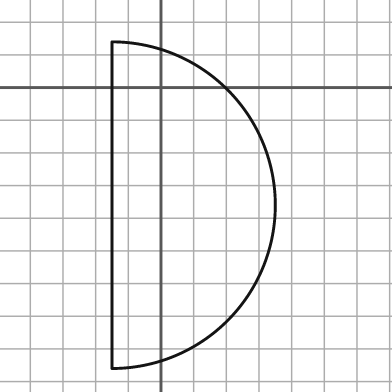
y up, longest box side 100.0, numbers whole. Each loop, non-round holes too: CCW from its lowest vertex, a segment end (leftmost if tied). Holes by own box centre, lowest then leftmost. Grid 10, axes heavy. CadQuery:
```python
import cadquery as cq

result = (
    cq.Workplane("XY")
    .moveTo(-15.0, -86.0)
    .threePointArc((35.0, -36.0), (-15.0, 14.0))
    .close()
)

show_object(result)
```